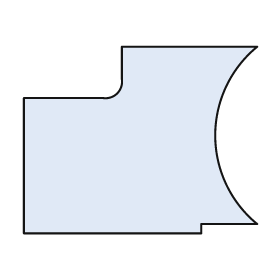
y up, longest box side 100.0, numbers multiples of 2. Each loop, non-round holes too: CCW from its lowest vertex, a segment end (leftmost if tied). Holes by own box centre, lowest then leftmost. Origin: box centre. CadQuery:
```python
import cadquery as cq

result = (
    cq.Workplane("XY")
    .moveTo(-50.0, -40.0)
    .lineTo(26.0, -40.0)
    .lineTo(26.0, -36.0)
    .lineTo(50.0, -36.0)
    .threePointArc((32.0, 2.0), (50.0, 40.0))
    .lineTo(-8.0, 40.0)
    .lineTo(-8.0, 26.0)
    .threePointArc((-10.0, 20.0), (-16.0, 18.0))
    .lineTo(-50.0, 18.0)
    .close()
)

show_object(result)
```